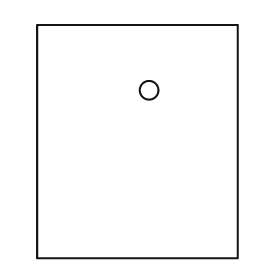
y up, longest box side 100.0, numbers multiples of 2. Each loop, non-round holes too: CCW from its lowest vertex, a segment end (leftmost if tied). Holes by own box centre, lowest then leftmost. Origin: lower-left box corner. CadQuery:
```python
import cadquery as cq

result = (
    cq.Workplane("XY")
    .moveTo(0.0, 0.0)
    .lineTo(86.0, 0.0)
    .lineTo(86.0, 100.0)
    .lineTo(0.0, 100.0)
    .close()
    .moveTo(48.0, 72.0)
    .circle(4.0)
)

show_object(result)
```